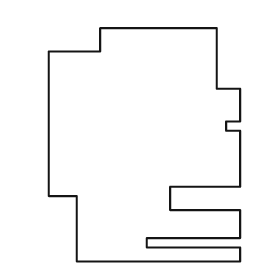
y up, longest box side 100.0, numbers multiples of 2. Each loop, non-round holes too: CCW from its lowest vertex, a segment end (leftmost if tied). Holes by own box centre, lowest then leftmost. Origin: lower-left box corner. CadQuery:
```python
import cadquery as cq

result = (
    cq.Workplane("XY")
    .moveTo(12.0, 0.0)
    .lineTo(82.0, 0.0)
    .lineTo(82.0, 6.0)
    .lineTo(42.0, 6.0)
    .lineTo(42.0, 10.0)
    .lineTo(82.0, 10.0)
    .lineTo(82.0, 22.0)
    .lineTo(52.0, 22.0)
    .lineTo(52.0, 32.0)
    .lineTo(82.0, 32.0)
    .lineTo(82.0, 56.0)
    .lineTo(76.0, 56.0)
    .lineTo(76.0, 60.0)
    .lineTo(82.0, 60.0)
    .lineTo(82.0, 74.0)
    .lineTo(72.0, 74.0)
    .lineTo(72.0, 100.0)
    .lineTo(22.0, 100.0)
    .lineTo(22.0, 90.0)
    .lineTo(0.0, 90.0)
    .lineTo(0.0, 28.0)
    .lineTo(12.0, 28.0)
    .close()
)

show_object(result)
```